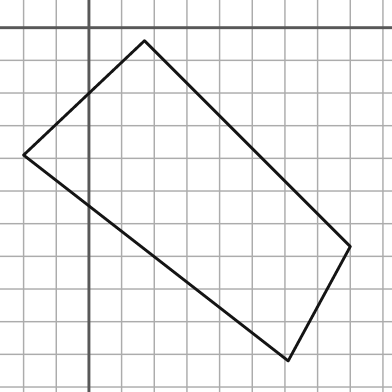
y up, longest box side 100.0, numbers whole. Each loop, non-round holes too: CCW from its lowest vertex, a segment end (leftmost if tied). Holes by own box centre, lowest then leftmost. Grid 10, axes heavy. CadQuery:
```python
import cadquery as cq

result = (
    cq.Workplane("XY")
    .moveTo(61.0, -102.0)
    .lineTo(80.0, -67.0)
    .lineTo(17.0, -4.0)
    .lineTo(-20.0, -39.0)
    .close()
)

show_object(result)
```